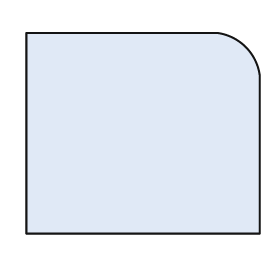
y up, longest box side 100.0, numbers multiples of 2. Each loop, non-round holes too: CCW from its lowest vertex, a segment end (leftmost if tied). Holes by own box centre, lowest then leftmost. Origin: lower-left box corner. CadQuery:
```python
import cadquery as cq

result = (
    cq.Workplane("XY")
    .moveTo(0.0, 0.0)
    .lineTo(100.0, 0.0)
    .lineTo(100.0, 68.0)
    .threePointArc((94.0, 80.0), (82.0, 86.0))
    .lineTo(0.0, 86.0)
    .close()
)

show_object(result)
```